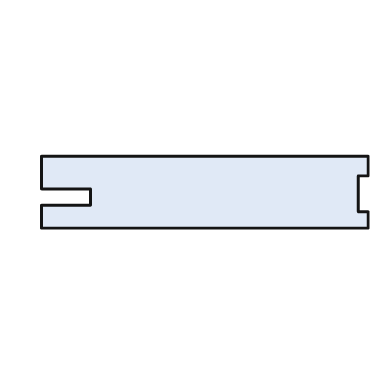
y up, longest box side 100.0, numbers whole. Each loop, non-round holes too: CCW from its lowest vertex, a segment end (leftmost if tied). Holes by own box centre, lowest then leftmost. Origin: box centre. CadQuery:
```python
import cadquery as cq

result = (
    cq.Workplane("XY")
    .moveTo(-50.0, -11.0)
    .lineTo(50.0, -11.0)
    .lineTo(50.0, -6.0)
    .lineTo(47.0, -6.0)
    .lineTo(47.0, 5.0)
    .lineTo(50.0, 5.0)
    .lineTo(50.0, 11.0)
    .lineTo(-50.0, 11.0)
    .lineTo(-50.0, 1.0)
    .lineTo(-35.0, 1.0)
    .lineTo(-35.0, -4.0)
    .lineTo(-50.0, -4.0)
    .close()
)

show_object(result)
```